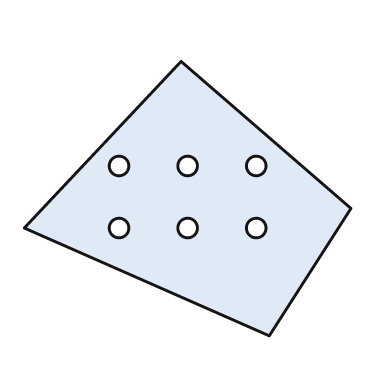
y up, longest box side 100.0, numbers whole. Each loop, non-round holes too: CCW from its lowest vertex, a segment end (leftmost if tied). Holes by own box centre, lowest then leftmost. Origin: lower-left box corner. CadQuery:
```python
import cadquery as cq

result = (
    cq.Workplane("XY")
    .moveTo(75.0, 0.0)
    .lineTo(100.0, 39.0)
    .lineTo(48.0, 84.0)
    .lineTo(0.0, 33.0)
    .close()
    .moveTo(29.0, 33.0)
    .circle(3.0)
    .moveTo(50.0, 33.0)
    .circle(3.0)
    .moveTo(71.0, 33.0)
    .circle(3.0)
    .moveTo(29.0, 52.0)
    .circle(3.0)
    .moveTo(50.0, 52.0)
    .circle(3.0)
    .moveTo(71.0, 52.0)
    .circle(3.0)
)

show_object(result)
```